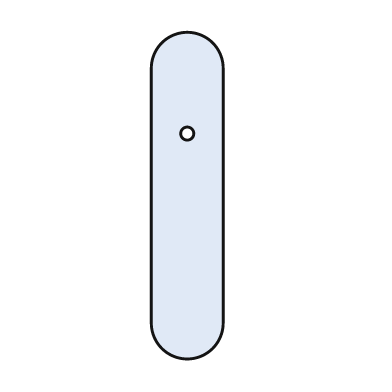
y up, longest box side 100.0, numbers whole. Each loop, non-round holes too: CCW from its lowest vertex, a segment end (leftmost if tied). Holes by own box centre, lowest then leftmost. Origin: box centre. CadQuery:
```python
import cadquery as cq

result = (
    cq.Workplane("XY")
    .moveTo(-11.0, -39.0)
    .threePointArc((0.0, -50.0), (11.0, -39.0))
    .lineTo(11.0, 39.0)
    .threePointArc((0.0, 50.0), (-11.0, 39.0))
    .close()
    .moveTo(0.0, 19.0)
    .circle(2.0)
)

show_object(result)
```